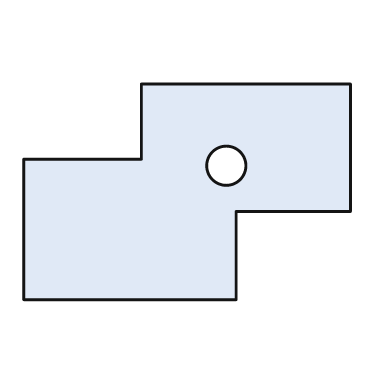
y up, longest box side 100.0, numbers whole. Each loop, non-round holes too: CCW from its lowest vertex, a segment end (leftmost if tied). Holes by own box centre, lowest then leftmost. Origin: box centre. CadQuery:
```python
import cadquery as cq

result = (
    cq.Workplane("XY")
    .moveTo(-50.0, -33.0)
    .lineTo(15.0, -33.0)
    .lineTo(15.0, -6.0)
    .lineTo(50.0, -6.0)
    .lineTo(50.0, 33.0)
    .lineTo(-14.0, 33.0)
    .lineTo(-14.0, 10.0)
    .lineTo(-50.0, 10.0)
    .close()
    .moveTo(12.0, 8.0)
    .circle(6.0)
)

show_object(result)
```